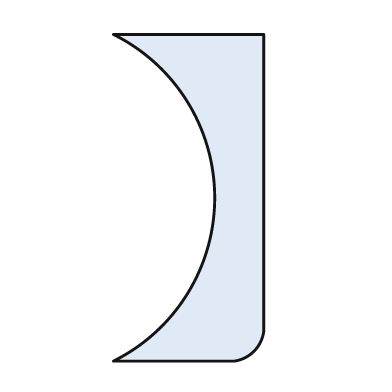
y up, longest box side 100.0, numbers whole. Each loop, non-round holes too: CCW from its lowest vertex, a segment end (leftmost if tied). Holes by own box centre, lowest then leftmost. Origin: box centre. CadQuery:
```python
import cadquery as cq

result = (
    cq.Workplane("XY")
    .moveTo(-23.0, -50.0)
    .lineTo(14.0, -50.0)
    .threePointArc((20.0, -47.0), (23.0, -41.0))
    .lineTo(23.0, 50.0)
    .lineTo(-23.0, 50.0)
    .threePointArc((8.0, 0.0), (-23.0, -50.0))
    .close()
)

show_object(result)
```